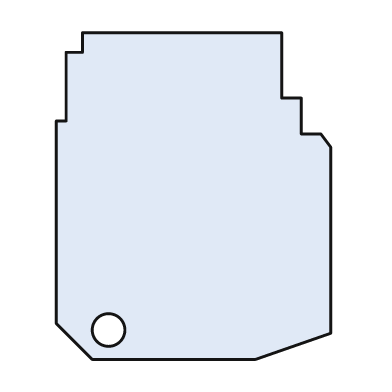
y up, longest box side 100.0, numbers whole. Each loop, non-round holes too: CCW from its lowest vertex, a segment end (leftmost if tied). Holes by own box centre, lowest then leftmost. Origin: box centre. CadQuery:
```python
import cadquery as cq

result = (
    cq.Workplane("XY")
    .moveTo(-31.0, -50.0)
    .lineTo(19.0, -50.0)
    .lineTo(42.0, -42.0)
    .lineTo(42.0, 15.0)
    .lineTo(39.0, 19.0)
    .lineTo(33.0, 19.0)
    .lineTo(33.0, 30.0)
    .lineTo(27.0, 30.0)
    .lineTo(27.0, 50.0)
    .lineTo(-34.0, 50.0)
    .lineTo(-34.0, 44.0)
    .lineTo(-39.0, 44.0)
    .lineTo(-39.0, 23.0)
    .lineTo(-42.0, 23.0)
    .lineTo(-42.0, -39.0)
    .close()
    .moveTo(-26.0, -41.0)
    .circle(5.0)
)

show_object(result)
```